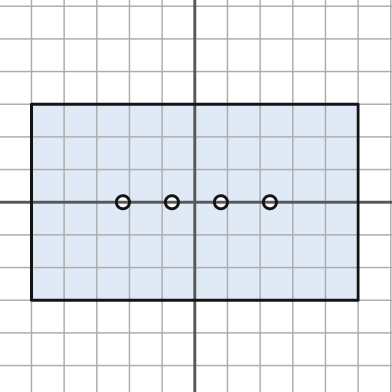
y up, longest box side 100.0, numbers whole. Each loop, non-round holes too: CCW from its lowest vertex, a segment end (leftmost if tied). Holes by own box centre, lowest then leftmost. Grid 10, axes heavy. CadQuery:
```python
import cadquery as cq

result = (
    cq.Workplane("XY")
    .moveTo(-50.0, -30.0)
    .lineTo(50.0, -30.0)
    .lineTo(50.0, 30.0)
    .lineTo(-50.0, 30.0)
    .close()
    .moveTo(-22.0, 0.0)
    .circle(2.0)
    .moveTo(-7.0, 0.0)
    .circle(2.0)
    .moveTo(8.0, 0.0)
    .circle(2.0)
    .moveTo(23.0, 0.0)
    .circle(2.0)
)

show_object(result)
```